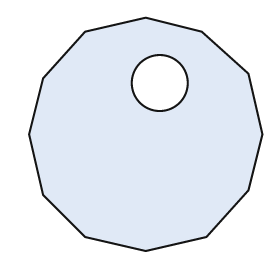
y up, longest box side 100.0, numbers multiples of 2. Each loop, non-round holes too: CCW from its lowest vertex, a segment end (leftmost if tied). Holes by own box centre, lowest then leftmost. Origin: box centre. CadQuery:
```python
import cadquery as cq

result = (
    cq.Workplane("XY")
    .moveTo(0.0, -50.0)
    .lineTo(26.0, -44.0)
    .lineTo(44.0, -24.0)
    .lineTo(50.0, 0.0)
    .lineTo(44.0, 26.0)
    .lineTo(24.0, 44.0)
    .lineTo(0.0, 50.0)
    .lineTo(-26.0, 44.0)
    .lineTo(-44.0, 24.0)
    .lineTo(-50.0, 0.0)
    .lineTo(-44.0, -26.0)
    .lineTo(-26.0, -44.0)
    .close()
    .moveTo(6.0, 22.0)
    .circle(12.0)
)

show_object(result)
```